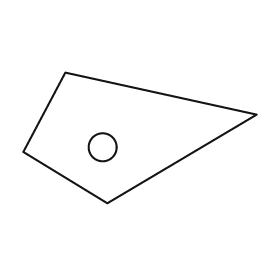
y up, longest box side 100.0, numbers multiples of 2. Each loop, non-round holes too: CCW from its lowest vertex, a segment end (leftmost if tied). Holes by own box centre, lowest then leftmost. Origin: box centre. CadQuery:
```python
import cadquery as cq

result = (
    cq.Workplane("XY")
    .moveTo(-14.0, -28.0)
    .lineTo(50.0, 10.0)
    .lineTo(-32.0, 28.0)
    .lineTo(-50.0, -6.0)
    .close()
    .moveTo(-16.0, -4.0)
    .circle(6.0)
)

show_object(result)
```